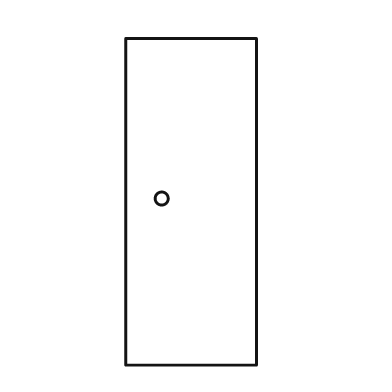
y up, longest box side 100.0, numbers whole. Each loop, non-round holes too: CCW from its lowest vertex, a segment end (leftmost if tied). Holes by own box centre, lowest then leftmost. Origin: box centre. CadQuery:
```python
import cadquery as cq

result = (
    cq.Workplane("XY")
    .moveTo(-20.0, -50.0)
    .lineTo(20.0, -50.0)
    .lineTo(20.0, 50.0)
    .lineTo(-20.0, 50.0)
    .close()
    .moveTo(-9.0, 1.0)
    .circle(2.0)
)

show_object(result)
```